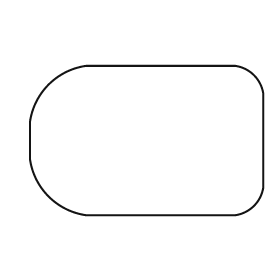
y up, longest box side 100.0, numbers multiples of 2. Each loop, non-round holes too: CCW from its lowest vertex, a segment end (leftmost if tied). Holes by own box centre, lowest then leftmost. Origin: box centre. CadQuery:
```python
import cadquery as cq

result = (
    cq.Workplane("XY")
    .moveTo(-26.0, -32.0)
    .lineTo(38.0, -32.0)
    .threePointArc((46.0, -28.0), (50.0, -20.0))
    .lineTo(50.0, 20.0)
    .threePointArc((46.0, 28.0), (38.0, 32.0))
    .lineTo(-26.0, 32.0)
    .threePointArc((-42.0, 24.0), (-50.0, 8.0))
    .lineTo(-50.0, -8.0)
    .threePointArc((-42.0, -24.0), (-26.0, -32.0))
    .close()
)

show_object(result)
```